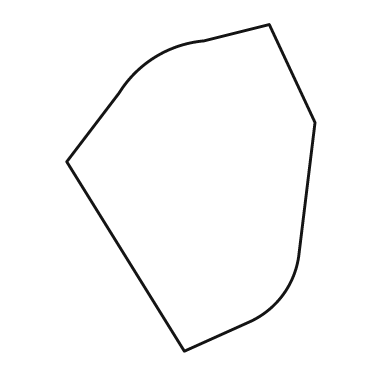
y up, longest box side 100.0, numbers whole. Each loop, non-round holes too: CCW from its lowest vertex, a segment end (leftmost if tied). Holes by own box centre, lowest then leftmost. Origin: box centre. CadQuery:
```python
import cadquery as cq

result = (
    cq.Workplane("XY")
    .moveTo(-2.0, -50.0)
    .lineTo(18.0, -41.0)
    .threePointArc((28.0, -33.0), (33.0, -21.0))
    .lineTo(38.0, 20.0)
    .lineTo(24.0, 50.0)
    .lineTo(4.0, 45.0)
    .threePointArc((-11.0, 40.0), (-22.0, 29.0))
    .lineTo(-38.0, 8.0)
    .close()
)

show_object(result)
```